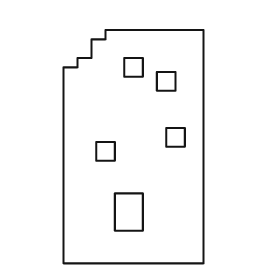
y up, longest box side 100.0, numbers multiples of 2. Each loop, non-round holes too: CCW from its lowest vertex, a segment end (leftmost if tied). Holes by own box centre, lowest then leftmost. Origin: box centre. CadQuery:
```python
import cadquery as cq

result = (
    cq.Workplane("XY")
    .moveTo(-30.0, -50.0)
    .lineTo(30.0, -50.0)
    .lineTo(30.0, 50.0)
    .lineTo(-12.0, 50.0)
    .lineTo(-12.0, 46.0)
    .lineTo(-18.0, 46.0)
    .lineTo(-18.0, 38.0)
    .lineTo(-24.0, 38.0)
    .lineTo(-24.0, 34.0)
    .lineTo(-30.0, 34.0)
    .close()
    .moveTo(-8.0, -36.0)
    .lineTo(4.0, -36.0)
    .lineTo(4.0, -20.0)
    .lineTo(-8.0, -20.0)
    .close()
    .moveTo(-16.0, -6.0)
    .lineTo(-8.0, -6.0)
    .lineTo(-8.0, 2.0)
    .lineTo(-16.0, 2.0)
    .close()
    .moveTo(14.0, 0.0)
    .lineTo(22.0, 0.0)
    .lineTo(22.0, 8.0)
    .lineTo(14.0, 8.0)
    .close()
    .moveTo(10.0, 24.0)
    .lineTo(18.0, 24.0)
    .lineTo(18.0, 32.0)
    .lineTo(10.0, 32.0)
    .close()
    .moveTo(-4.0, 30.0)
    .lineTo(4.0, 30.0)
    .lineTo(4.0, 38.0)
    .lineTo(-4.0, 38.0)
    .close()
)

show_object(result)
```